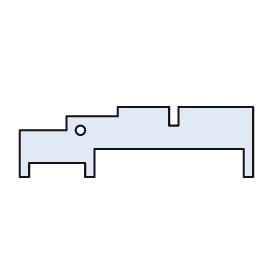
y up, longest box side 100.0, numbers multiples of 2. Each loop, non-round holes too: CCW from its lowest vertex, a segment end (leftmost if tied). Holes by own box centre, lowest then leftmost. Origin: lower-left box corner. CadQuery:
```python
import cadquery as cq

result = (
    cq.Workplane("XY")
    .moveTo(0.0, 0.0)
    .lineTo(4.0, 0.0)
    .lineTo(4.0, 6.0)
    .lineTo(28.0, 6.0)
    .lineTo(28.0, 0.0)
    .lineTo(32.0, 0.0)
    .lineTo(32.0, 12.0)
    .lineTo(96.0, 12.0)
    .lineTo(96.0, 0.0)
    .lineTo(100.0, 0.0)
    .lineTo(100.0, 30.0)
    .lineTo(68.0, 30.0)
    .lineTo(68.0, 22.0)
    .lineTo(64.0, 22.0)
    .lineTo(64.0, 30.0)
    .lineTo(42.0, 30.0)
    .lineTo(42.0, 26.0)
    .lineTo(20.0, 26.0)
    .lineTo(20.0, 20.0)
    .lineTo(0.0, 20.0)
    .close()
    .moveTo(26.0, 20.0)
    .circle(2.0)
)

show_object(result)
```